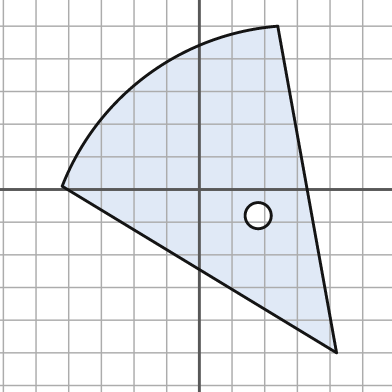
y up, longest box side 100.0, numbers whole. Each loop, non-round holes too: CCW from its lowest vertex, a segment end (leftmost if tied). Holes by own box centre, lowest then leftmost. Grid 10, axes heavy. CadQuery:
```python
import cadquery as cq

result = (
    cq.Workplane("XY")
    .moveTo(42.0, -50.0)
    .lineTo(24.0, 50.0)
    .threePointArc((-16.0, 35.0), (-42.0, 1.0))
    .close()
    .moveTo(18.0, -8.0)
    .circle(4.0)
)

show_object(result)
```